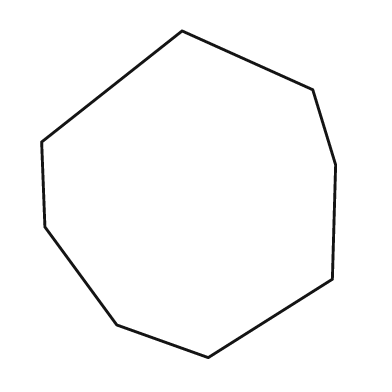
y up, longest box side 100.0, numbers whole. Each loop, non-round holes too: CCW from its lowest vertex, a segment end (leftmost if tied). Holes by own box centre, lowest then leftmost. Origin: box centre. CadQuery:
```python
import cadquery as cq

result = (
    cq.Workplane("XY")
    .moveTo(6.0, -50.0)
    .lineTo(44.0, -26.0)
    .lineTo(45.0, 9.0)
    .lineTo(38.0, 32.0)
    .lineTo(-2.0, 50.0)
    .lineTo(-45.0, 16.0)
    .lineTo(-44.0, -10.0)
    .lineTo(-22.0, -40.0)
    .close()
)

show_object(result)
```